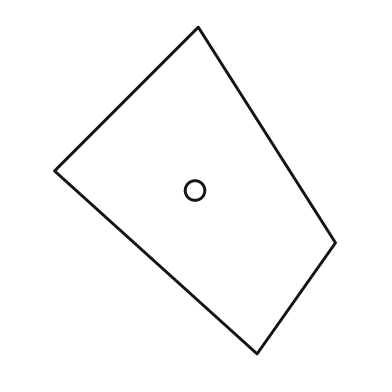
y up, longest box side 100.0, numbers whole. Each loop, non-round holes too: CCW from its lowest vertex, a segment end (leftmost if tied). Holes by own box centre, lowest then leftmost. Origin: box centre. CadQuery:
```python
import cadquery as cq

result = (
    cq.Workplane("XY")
    .moveTo(19.0, -50.0)
    .lineTo(43.0, -16.0)
    .lineTo(1.0, 50.0)
    .lineTo(-43.0, 6.0)
    .close()
    .moveTo(0.0, 0.0)
    .circle(3.0)
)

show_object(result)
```